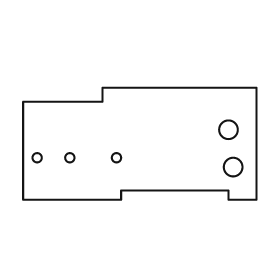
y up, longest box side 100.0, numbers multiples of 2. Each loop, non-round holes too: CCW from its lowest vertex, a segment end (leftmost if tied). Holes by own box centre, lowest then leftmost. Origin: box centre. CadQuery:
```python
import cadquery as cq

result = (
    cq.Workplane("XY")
    .moveTo(-50.0, -24.0)
    .lineTo(-8.0, -24.0)
    .lineTo(-8.0, -20.0)
    .lineTo(38.0, -20.0)
    .lineTo(38.0, -24.0)
    .lineTo(50.0, -24.0)
    .lineTo(50.0, 24.0)
    .lineTo(-16.0, 24.0)
    .lineTo(-16.0, 18.0)
    .lineTo(-50.0, 18.0)
    .close()
    .moveTo(40.0, -10.0)
    .circle(4.0)
    .moveTo(-44.0, -6.0)
    .circle(2.0)
    .moveTo(-30.0, -6.0)
    .circle(2.0)
    .moveTo(-10.0, -6.0)
    .circle(2.0)
    .moveTo(38.0, 6.0)
    .circle(4.0)
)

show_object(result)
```